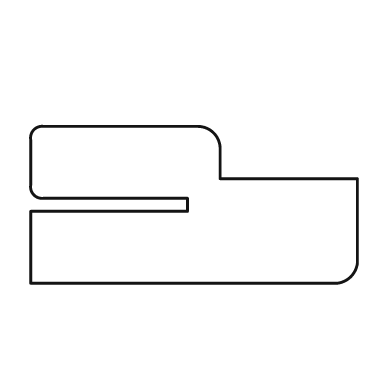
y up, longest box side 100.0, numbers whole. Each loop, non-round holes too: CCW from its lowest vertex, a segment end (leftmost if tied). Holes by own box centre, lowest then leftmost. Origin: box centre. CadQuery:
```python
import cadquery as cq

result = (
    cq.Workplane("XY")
    .moveTo(-50.0, -24.0)
    .lineTo(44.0, -24.0)
    .threePointArc((48.0, -22.0), (50.0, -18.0))
    .lineTo(50.0, 8.0)
    .lineTo(8.0, 8.0)
    .lineTo(8.0, 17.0)
    .threePointArc((6.0, 22.0), (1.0, 24.0))
    .lineTo(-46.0, 24.0)
    .threePointArc((-49.0, 23.0), (-50.0, 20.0))
    .lineTo(-50.0, 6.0)
    .threePointArc((-49.0, 3.0), (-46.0, 2.0))
    .lineTo(-2.0, 2.0)
    .lineTo(-2.0, -2.0)
    .lineTo(-50.0, -2.0)
    .close()
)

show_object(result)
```